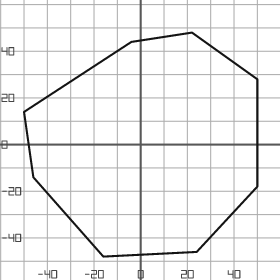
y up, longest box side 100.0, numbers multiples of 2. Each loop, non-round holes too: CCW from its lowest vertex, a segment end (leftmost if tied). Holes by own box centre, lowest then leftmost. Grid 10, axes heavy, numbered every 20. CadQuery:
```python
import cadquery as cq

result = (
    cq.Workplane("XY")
    .moveTo(-16.0, -48.0)
    .lineTo(24.0, -46.0)
    .lineTo(50.0, -18.0)
    .lineTo(50.0, 28.0)
    .lineTo(22.0, 48.0)
    .lineTo(-4.0, 44.0)
    .lineTo(-50.0, 14.0)
    .lineTo(-46.0, -14.0)
    .close()
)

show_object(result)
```